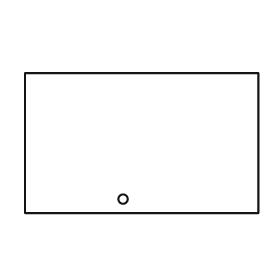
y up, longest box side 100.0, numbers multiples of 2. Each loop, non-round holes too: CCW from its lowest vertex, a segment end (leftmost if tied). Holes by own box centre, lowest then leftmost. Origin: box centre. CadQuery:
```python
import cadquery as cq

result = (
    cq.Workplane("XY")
    .moveTo(-50.0, -30.0)
    .lineTo(50.0, -30.0)
    .lineTo(50.0, 30.0)
    .lineTo(-50.0, 30.0)
    .close()
    .moveTo(-8.0, -24.0)
    .circle(2.0)
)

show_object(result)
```